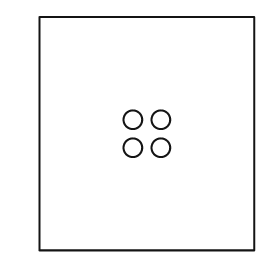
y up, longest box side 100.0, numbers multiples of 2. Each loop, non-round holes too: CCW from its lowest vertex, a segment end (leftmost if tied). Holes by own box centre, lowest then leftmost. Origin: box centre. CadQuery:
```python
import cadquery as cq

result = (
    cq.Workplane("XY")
    .moveTo(-46.0, -50.0)
    .lineTo(46.0, -50.0)
    .lineTo(46.0, 50.0)
    .lineTo(-46.0, 50.0)
    .close()
    .moveTo(-6.0, -6.0)
    .circle(4.0)
    .moveTo(6.0, -6.0)
    .circle(4.0)
    .moveTo(-6.0, 6.0)
    .circle(4.0)
    .moveTo(6.0, 6.0)
    .circle(4.0)
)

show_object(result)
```